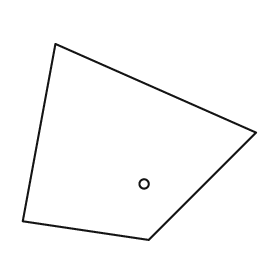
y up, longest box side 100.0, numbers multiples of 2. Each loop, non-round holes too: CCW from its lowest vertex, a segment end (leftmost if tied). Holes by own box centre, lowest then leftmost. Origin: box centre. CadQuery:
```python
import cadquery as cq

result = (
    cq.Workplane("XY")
    .moveTo(4.0, -42.0)
    .lineTo(50.0, 4.0)
    .lineTo(-36.0, 42.0)
    .lineTo(-50.0, -34.0)
    .close()
    .moveTo(2.0, -18.0)
    .circle(2.0)
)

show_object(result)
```